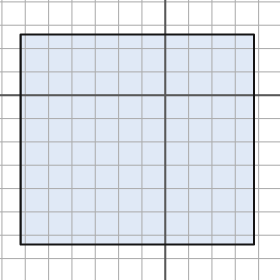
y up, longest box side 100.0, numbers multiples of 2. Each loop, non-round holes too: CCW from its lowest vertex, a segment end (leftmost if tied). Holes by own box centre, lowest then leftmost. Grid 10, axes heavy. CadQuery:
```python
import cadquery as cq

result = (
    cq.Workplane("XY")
    .moveTo(-62.0, -64.0)
    .lineTo(38.0, -64.0)
    .lineTo(38.0, 26.0)
    .lineTo(-62.0, 26.0)
    .close()
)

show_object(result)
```